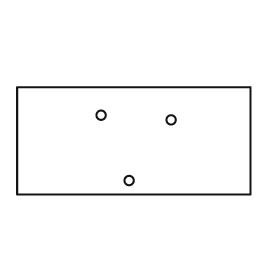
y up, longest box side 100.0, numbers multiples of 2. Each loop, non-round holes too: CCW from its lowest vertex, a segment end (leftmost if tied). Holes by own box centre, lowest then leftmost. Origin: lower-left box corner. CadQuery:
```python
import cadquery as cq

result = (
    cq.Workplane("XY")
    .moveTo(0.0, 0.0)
    .lineTo(100.0, 0.0)
    .lineTo(100.0, 46.0)
    .lineTo(0.0, 46.0)
    .close()
    .moveTo(48.0, 6.0)
    .circle(2.0)
    .moveTo(66.0, 32.0)
    .circle(2.0)
    .moveTo(36.0, 34.0)
    .circle(2.0)
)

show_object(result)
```